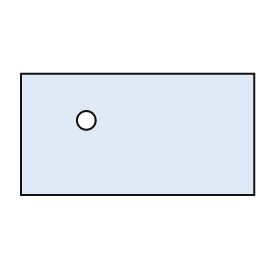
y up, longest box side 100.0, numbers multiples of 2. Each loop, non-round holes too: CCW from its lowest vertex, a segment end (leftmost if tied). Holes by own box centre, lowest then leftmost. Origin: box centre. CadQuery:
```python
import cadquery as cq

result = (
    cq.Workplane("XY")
    .moveTo(-50.0, -26.0)
    .lineTo(50.0, -26.0)
    .lineTo(50.0, 26.0)
    .lineTo(-50.0, 26.0)
    .close()
    .moveTo(-22.0, 6.0)
    .circle(4.0)
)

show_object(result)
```